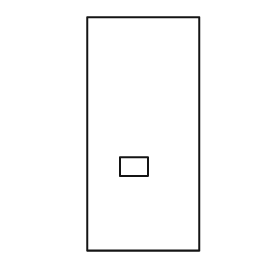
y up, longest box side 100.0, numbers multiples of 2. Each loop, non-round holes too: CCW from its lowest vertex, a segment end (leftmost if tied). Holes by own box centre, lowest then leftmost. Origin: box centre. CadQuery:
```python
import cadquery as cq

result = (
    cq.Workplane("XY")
    .moveTo(-24.0, -50.0)
    .lineTo(24.0, -50.0)
    .lineTo(24.0, 50.0)
    .lineTo(-24.0, 50.0)
    .close()
    .moveTo(-10.0, -18.0)
    .lineTo(2.0, -18.0)
    .lineTo(2.0, -10.0)
    .lineTo(-10.0, -10.0)
    .close()
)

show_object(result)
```